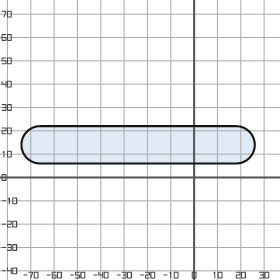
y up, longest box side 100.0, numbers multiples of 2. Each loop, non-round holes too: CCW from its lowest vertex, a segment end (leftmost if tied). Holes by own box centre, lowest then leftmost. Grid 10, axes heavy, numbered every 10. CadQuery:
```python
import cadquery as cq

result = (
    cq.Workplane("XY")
    .moveTo(-66.0, 6.0)
    .lineTo(18.0, 6.0)
    .threePointArc((26.0, 14.0), (18.0, 22.0))
    .lineTo(-66.0, 22.0)
    .threePointArc((-74.0, 14.0), (-66.0, 6.0))
    .close()
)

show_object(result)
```